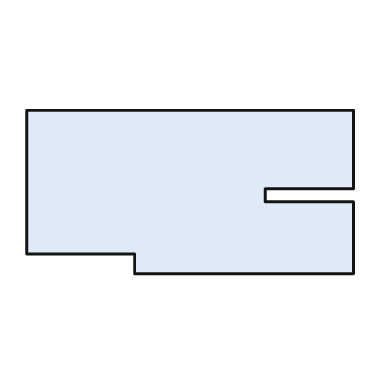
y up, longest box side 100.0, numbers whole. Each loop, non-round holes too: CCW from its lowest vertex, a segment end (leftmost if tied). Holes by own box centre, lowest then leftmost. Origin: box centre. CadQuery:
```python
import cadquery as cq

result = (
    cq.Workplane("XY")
    .moveTo(-17.0, -25.0)
    .lineTo(50.0, -25.0)
    .lineTo(50.0, -3.0)
    .lineTo(23.0, -3.0)
    .lineTo(23.0, 1.0)
    .lineTo(50.0, 1.0)
    .lineTo(50.0, 25.0)
    .lineTo(-50.0, 25.0)
    .lineTo(-50.0, -19.0)
    .lineTo(-17.0, -19.0)
    .close()
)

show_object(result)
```